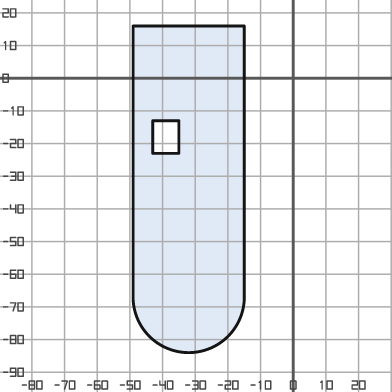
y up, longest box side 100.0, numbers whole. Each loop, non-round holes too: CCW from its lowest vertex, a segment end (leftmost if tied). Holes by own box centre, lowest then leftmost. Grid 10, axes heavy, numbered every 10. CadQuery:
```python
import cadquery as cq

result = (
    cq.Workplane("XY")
    .moveTo(-49.0, -68.0)
    .threePointArc((-32.0, -84.0), (-15.0, -68.0))
    .lineTo(-15.0, 16.0)
    .lineTo(-49.0, 16.0)
    .close()
    .moveTo(-43.0, -23.0)
    .lineTo(-35.0, -23.0)
    .lineTo(-35.0, -13.0)
    .lineTo(-43.0, -13.0)
    .close()
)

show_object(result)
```